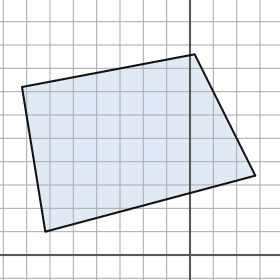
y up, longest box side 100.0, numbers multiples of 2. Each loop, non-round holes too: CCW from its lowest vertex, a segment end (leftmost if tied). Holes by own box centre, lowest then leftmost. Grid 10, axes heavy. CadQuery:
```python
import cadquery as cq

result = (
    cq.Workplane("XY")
    .moveTo(-62.0, 10.0)
    .lineTo(28.0, 34.0)
    .lineTo(2.0, 86.0)
    .lineTo(-72.0, 72.0)
    .close()
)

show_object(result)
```